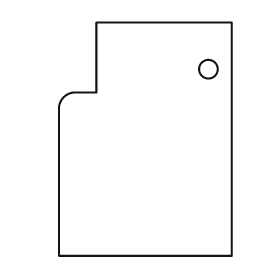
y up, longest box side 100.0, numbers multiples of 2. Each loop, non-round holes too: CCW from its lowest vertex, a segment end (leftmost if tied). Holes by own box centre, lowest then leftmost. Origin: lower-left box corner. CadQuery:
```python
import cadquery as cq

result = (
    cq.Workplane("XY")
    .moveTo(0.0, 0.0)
    .lineTo(74.0, 0.0)
    .lineTo(74.0, 100.0)
    .lineTo(16.0, 100.0)
    .lineTo(16.0, 70.0)
    .lineTo(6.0, 70.0)
    .threePointArc((2.0, 68.0), (0.0, 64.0))
    .close()
    .moveTo(64.0, 80.0)
    .circle(4.0)
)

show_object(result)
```